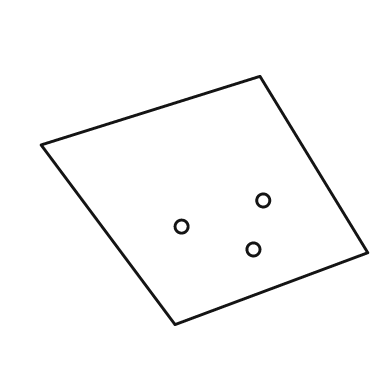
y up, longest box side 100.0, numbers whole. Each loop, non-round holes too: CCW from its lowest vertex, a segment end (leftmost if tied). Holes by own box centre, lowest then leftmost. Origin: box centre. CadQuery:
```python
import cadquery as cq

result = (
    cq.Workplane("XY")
    .moveTo(-9.0, -38.0)
    .lineTo(50.0, -16.0)
    .lineTo(17.0, 38.0)
    .lineTo(-50.0, 17.0)
    .close()
    .moveTo(15.0, -15.0)
    .circle(2.0)
    .moveTo(-7.0, -8.0)
    .circle(2.0)
    .moveTo(18.0, 0.0)
    .circle(2.0)
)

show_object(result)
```